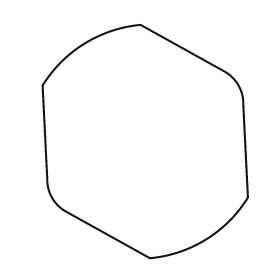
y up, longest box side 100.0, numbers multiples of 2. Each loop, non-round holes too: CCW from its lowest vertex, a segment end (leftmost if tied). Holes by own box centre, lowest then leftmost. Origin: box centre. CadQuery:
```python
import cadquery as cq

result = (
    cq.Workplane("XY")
    .moveTo(2.0, -50.0)
    .threePointArc((26.0, -42.0), (44.0, -24.0))
    .lineTo(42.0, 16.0)
    .threePointArc((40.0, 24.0), (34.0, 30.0))
    .lineTo(-2.0, 50.0)
    .threePointArc((-26.0, 42.0), (-44.0, 24.0))
    .lineTo(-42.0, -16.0)
    .threePointArc((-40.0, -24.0), (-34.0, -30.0))
    .close()
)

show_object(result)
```